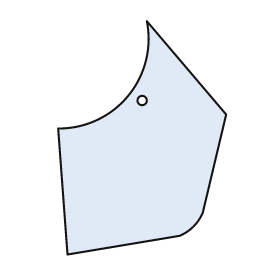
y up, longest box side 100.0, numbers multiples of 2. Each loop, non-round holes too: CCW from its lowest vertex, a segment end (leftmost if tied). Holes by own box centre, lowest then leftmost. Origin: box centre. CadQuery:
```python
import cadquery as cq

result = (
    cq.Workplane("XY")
    .moveTo(-32.0, -50.0)
    .lineTo(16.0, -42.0)
    .threePointArc((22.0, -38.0), (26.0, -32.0))
    .lineTo(36.0, 10.0)
    .lineTo(2.0, 50.0)
    .threePointArc((-6.0, 18.0), (-36.0, 4.0))
    .close()
    .moveTo(0.0, 16.0)
    .circle(2.0)
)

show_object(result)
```